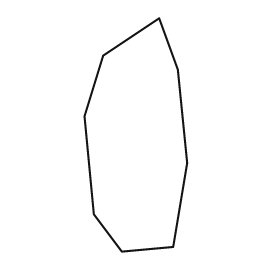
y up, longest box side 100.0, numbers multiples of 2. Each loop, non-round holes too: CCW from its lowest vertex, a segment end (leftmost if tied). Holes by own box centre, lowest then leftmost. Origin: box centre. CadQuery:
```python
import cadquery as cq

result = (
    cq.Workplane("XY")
    .moveTo(-6.0, -50.0)
    .lineTo(16.0, -48.0)
    .lineTo(22.0, -12.0)
    .lineTo(18.0, 28.0)
    .lineTo(10.0, 50.0)
    .lineTo(-14.0, 34.0)
    .lineTo(-22.0, 8.0)
    .lineTo(-18.0, -34.0)
    .close()
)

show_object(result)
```